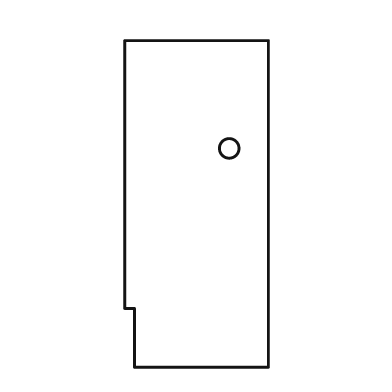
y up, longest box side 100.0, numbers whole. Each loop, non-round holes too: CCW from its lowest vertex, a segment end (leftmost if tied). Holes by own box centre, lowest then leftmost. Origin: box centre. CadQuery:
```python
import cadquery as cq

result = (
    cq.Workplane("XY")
    .moveTo(-19.0, -50.0)
    .lineTo(22.0, -50.0)
    .lineTo(22.0, 50.0)
    .lineTo(-22.0, 50.0)
    .lineTo(-22.0, -32.0)
    .lineTo(-19.0, -32.0)
    .close()
    .moveTo(10.0, 17.0)
    .circle(3.0)
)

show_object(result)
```